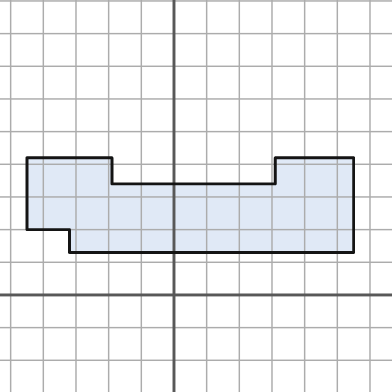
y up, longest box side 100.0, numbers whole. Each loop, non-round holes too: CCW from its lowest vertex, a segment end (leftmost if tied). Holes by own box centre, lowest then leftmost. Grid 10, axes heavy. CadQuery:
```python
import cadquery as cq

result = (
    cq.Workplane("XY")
    .moveTo(-32.0, 13.0)
    .lineTo(55.0, 13.0)
    .lineTo(55.0, 42.0)
    .lineTo(31.0, 42.0)
    .lineTo(31.0, 34.0)
    .lineTo(-19.0, 34.0)
    .lineTo(-19.0, 42.0)
    .lineTo(-45.0, 42.0)
    .lineTo(-45.0, 20.0)
    .lineTo(-32.0, 20.0)
    .close()
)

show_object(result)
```